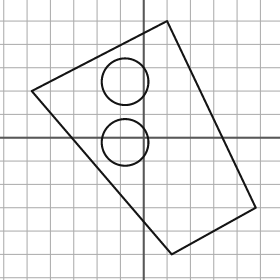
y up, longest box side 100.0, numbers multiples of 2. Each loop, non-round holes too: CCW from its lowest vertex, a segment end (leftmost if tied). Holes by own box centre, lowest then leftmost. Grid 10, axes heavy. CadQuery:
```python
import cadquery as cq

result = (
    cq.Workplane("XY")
    .moveTo(12.0, -50.0)
    .lineTo(48.0, -30.0)
    .lineTo(10.0, 50.0)
    .lineTo(-48.0, 20.0)
    .close()
    .moveTo(-8.0, -2.0)
    .circle(10.0)
    .moveTo(-8.0, 24.0)
    .circle(10.0)
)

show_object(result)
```